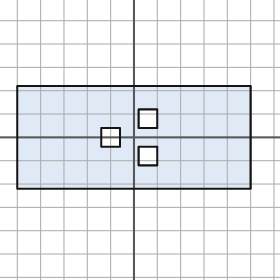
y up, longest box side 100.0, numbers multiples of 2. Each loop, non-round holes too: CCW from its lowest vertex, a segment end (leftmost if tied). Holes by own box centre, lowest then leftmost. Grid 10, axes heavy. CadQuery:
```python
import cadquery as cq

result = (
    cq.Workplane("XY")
    .moveTo(-50.0, -22.0)
    .lineTo(50.0, -22.0)
    .lineTo(50.0, 22.0)
    .lineTo(-50.0, 22.0)
    .close()
    .moveTo(2.0, -12.0)
    .lineTo(10.0, -12.0)
    .lineTo(10.0, -4.0)
    .lineTo(2.0, -4.0)
    .close()
    .moveTo(-14.0, -4.0)
    .lineTo(-6.0, -4.0)
    .lineTo(-6.0, 4.0)
    .lineTo(-14.0, 4.0)
    .close()
    .moveTo(2.0, 4.0)
    .lineTo(10.0, 4.0)
    .lineTo(10.0, 12.0)
    .lineTo(2.0, 12.0)
    .close()
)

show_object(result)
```